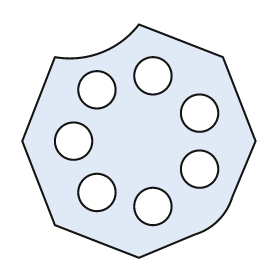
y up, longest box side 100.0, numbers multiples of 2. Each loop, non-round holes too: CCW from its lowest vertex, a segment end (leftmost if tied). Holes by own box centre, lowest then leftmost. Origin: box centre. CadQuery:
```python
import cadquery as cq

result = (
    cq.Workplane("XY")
    .moveTo(0.0, -50.0)
    .lineTo(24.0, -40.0)
    .threePointArc((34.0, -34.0), (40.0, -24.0))
    .lineTo(50.0, 0.0)
    .lineTo(36.0, 36.0)
    .lineTo(0.0, 50.0)
    .threePointArc((-16.0, 38.0), (-36.0, 36.0))
    .lineTo(-50.0, 0.0)
    .lineTo(-36.0, -36.0)
    .close()
    .moveTo(6.0, -28.0)
    .circle(8.0)
    .moveTo(-18.0, -22.0)
    .circle(8.0)
    .moveTo(26.0, -12.0)
    .circle(8.0)
    .moveTo(-28.0, 0.0)
    .circle(8.0)
    .moveTo(26.0, 12.0)
    .circle(8.0)
    .moveTo(-18.0, 22.0)
    .circle(8.0)
    .moveTo(6.0, 28.0)
    .circle(8.0)
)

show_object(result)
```